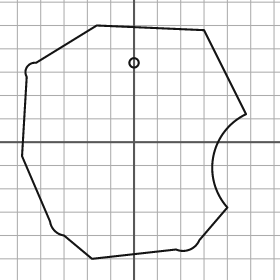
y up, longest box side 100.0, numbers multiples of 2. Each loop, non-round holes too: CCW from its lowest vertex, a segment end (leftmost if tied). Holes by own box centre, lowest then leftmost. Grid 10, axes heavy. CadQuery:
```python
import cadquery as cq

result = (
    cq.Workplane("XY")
    .moveTo(-18.0, -50.0)
    .lineTo(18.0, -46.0)
    .threePointArc((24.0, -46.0), (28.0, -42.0))
    .lineTo(40.0, -28.0)
    .threePointArc((34.0, -6.0), (48.0, 12.0))
    .lineTo(30.0, 48.0)
    .lineTo(-16.0, 50.0)
    .lineTo(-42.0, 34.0)
    .threePointArc((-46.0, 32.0), (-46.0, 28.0))
    .lineTo(-48.0, -6.0)
    .lineTo(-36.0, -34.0)
    .threePointArc((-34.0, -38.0), (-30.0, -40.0))
    .close()
    .moveTo(0.0, 34.0)
    .circle(2.0)
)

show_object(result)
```